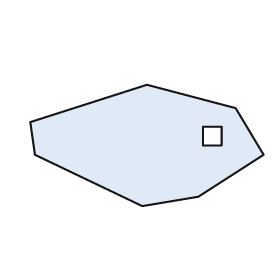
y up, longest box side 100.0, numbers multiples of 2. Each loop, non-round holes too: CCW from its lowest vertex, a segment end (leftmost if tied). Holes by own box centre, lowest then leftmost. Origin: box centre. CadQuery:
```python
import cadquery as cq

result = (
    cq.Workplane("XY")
    .moveTo(-2.0, -26.0)
    .lineTo(22.0, -22.0)
    .lineTo(50.0, -4.0)
    .lineTo(38.0, 16.0)
    .lineTo(0.0, 26.0)
    .lineTo(-50.0, 10.0)
    .lineTo(-48.0, -4.0)
    .close()
    .moveTo(24.0, 0.0)
    .lineTo(32.0, 0.0)
    .lineTo(32.0, 8.0)
    .lineTo(24.0, 8.0)
    .close()
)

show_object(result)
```